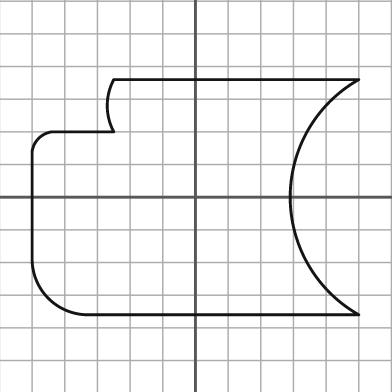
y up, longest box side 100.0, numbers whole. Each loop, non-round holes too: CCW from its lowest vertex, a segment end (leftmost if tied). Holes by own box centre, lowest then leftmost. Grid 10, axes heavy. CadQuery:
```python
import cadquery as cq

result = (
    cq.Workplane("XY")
    .moveTo(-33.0, -36.0)
    .lineTo(50.0, -36.0)
    .threePointArc((29.0, 0.0), (50.0, 36.0))
    .lineTo(-25.0, 36.0)
    .threePointArc((-27.0, 28.0), (-25.0, 20.0))
    .lineTo(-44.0, 20.0)
    .threePointArc((-48.0, 18.0), (-50.0, 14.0))
    .lineTo(-50.0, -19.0)
    .threePointArc((-45.0, -31.0), (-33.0, -36.0))
    .close()
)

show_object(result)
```